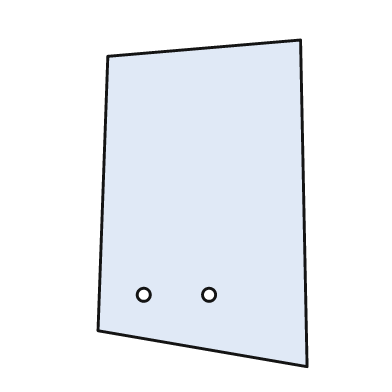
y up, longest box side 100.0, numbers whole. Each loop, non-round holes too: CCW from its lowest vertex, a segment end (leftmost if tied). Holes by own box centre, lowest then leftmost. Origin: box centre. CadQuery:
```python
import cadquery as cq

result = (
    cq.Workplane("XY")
    .moveTo(32.0, -50.0)
    .lineTo(30.0, 50.0)
    .lineTo(-29.0, 45.0)
    .lineTo(-32.0, -39.0)
    .close()
    .moveTo(-18.0, -28.0)
    .circle(2.0)
    .moveTo(2.0, -28.0)
    .circle(2.0)
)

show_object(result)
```